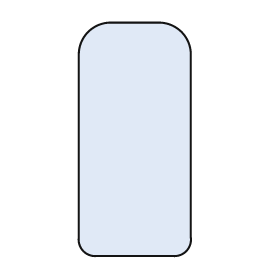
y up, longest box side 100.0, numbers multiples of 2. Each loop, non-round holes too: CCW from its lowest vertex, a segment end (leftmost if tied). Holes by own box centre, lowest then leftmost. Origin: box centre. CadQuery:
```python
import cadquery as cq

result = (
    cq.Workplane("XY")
    .moveTo(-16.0, -50.0)
    .lineTo(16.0, -50.0)
    .threePointArc((22.0, -48.0), (24.0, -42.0))
    .lineTo(24.0, 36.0)
    .threePointArc((20.0, 46.0), (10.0, 50.0))
    .lineTo(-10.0, 50.0)
    .threePointArc((-20.0, 46.0), (-24.0, 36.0))
    .lineTo(-24.0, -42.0)
    .threePointArc((-22.0, -48.0), (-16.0, -50.0))
    .close()
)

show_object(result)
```